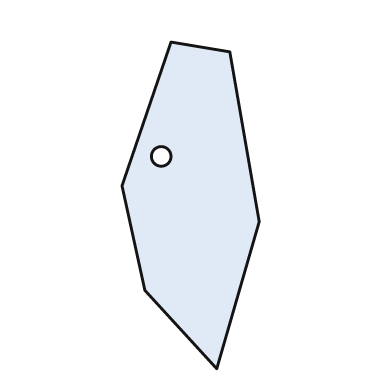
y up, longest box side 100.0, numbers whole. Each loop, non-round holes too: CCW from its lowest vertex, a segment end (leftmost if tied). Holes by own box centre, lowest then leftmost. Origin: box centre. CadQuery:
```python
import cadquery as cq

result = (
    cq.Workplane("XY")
    .moveTo(8.0, -50.0)
    .lineTo(21.0, -5.0)
    .lineTo(12.0, 47.0)
    .lineTo(-6.0, 50.0)
    .lineTo(-21.0, 6.0)
    .lineTo(-14.0, -26.0)
    .close()
    .moveTo(-9.0, 15.0)
    .circle(3.0)
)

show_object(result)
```